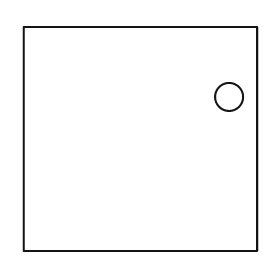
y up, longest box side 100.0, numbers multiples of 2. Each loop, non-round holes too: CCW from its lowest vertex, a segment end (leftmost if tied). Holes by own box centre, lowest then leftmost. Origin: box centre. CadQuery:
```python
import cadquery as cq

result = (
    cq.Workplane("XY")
    .moveTo(-50.0, -48.0)
    .lineTo(50.0, -48.0)
    .lineTo(50.0, 48.0)
    .lineTo(-50.0, 48.0)
    .close()
    .moveTo(38.0, 18.0)
    .circle(6.0)
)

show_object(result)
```